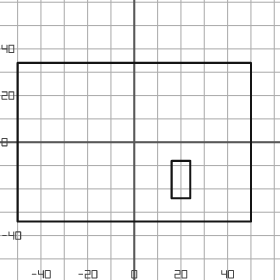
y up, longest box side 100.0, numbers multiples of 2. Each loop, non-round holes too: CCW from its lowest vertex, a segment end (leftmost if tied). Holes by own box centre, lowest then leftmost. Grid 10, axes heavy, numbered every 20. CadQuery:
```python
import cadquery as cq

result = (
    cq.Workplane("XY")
    .moveTo(-50.0, -34.0)
    .lineTo(50.0, -34.0)
    .lineTo(50.0, 34.0)
    .lineTo(-50.0, 34.0)
    .close()
    .moveTo(16.0, -24.0)
    .lineTo(24.0, -24.0)
    .lineTo(24.0, -8.0)
    .lineTo(16.0, -8.0)
    .close()
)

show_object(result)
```